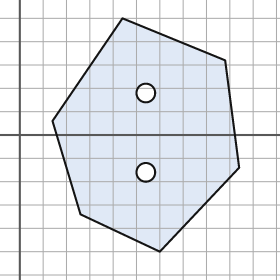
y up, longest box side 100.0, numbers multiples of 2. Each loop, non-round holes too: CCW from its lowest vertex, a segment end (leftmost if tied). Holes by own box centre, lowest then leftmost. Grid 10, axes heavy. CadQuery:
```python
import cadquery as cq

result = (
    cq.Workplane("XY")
    .moveTo(60.0, -50.0)
    .lineTo(94.0, -14.0)
    .lineTo(88.0, 32.0)
    .lineTo(44.0, 50.0)
    .lineTo(14.0, 6.0)
    .lineTo(26.0, -34.0)
    .close()
    .moveTo(54.0, -16.0)
    .circle(4.0)
    .moveTo(54.0, 18.0)
    .circle(4.0)
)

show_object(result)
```